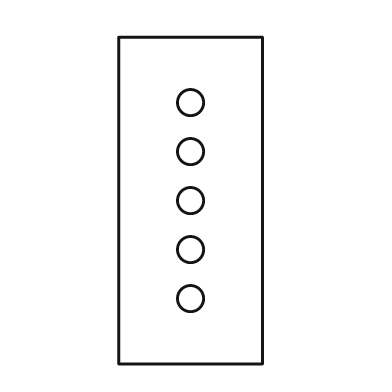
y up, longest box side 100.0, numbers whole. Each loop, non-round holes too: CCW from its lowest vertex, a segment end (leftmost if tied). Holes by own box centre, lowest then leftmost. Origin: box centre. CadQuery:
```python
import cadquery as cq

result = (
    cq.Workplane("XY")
    .moveTo(-22.0, -50.0)
    .lineTo(22.0, -50.0)
    .lineTo(22.0, 50.0)
    .lineTo(-22.0, 50.0)
    .close()
    .moveTo(0.0, -30.0)
    .circle(4.0)
    .moveTo(0.0, -15.0)
    .circle(4.0)
    .moveTo(0.0, 0.0)
    .circle(4.0)
    .moveTo(0.0, 15.0)
    .circle(4.0)
    .moveTo(0.0, 30.0)
    .circle(4.0)
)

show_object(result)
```